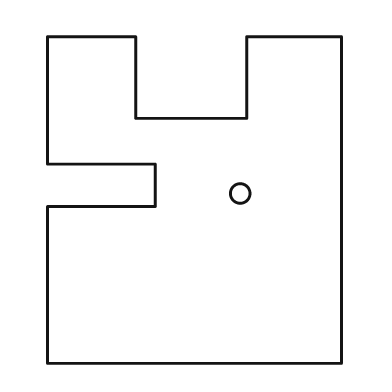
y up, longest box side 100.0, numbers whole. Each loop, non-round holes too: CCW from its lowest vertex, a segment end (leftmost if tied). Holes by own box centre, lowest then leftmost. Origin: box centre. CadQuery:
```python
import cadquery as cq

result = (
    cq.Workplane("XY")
    .moveTo(-45.0, -50.0)
    .lineTo(45.0, -50.0)
    .lineTo(45.0, 50.0)
    .lineTo(16.0, 50.0)
    .lineTo(16.0, 25.0)
    .lineTo(-18.0, 25.0)
    .lineTo(-18.0, 50.0)
    .lineTo(-45.0, 50.0)
    .lineTo(-45.0, 11.0)
    .lineTo(-12.0, 11.0)
    .lineTo(-12.0, -2.0)
    .lineTo(-45.0, -2.0)
    .close()
    .moveTo(14.0, 2.0)
    .circle(3.0)
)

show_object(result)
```